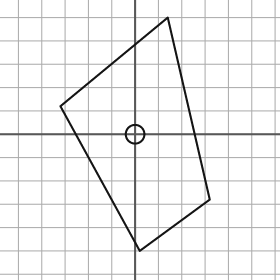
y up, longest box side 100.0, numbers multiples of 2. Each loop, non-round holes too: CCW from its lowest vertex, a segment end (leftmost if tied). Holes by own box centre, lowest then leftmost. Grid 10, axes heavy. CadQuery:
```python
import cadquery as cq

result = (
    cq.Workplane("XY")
    .moveTo(2.0, -50.0)
    .lineTo(32.0, -28.0)
    .lineTo(14.0, 50.0)
    .lineTo(-32.0, 12.0)
    .close()
    .moveTo(0.0, 0.0)
    .circle(4.0)
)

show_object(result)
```